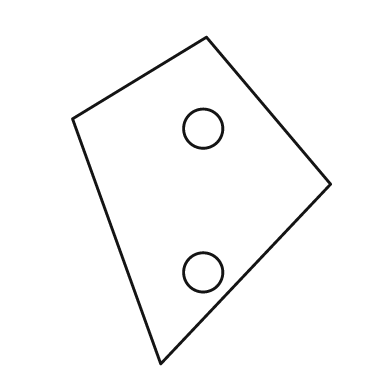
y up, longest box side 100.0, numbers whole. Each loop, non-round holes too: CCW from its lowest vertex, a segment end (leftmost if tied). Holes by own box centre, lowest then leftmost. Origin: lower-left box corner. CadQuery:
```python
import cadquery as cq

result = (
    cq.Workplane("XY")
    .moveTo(27.0, 0.0)
    .lineTo(79.0, 55.0)
    .lineTo(41.0, 100.0)
    .lineTo(0.0, 75.0)
    .close()
    .moveTo(40.0, 28.0)
    .circle(6.0)
    .moveTo(40.0, 72.0)
    .circle(6.0)
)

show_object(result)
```